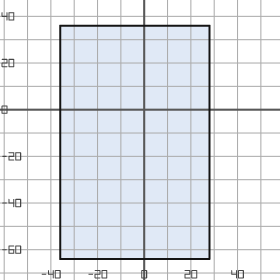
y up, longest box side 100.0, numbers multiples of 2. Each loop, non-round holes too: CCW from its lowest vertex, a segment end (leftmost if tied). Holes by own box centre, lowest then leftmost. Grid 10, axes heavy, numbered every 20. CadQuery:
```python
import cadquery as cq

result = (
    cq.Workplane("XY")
    .moveTo(-36.0, -64.0)
    .lineTo(28.0, -64.0)
    .lineTo(28.0, 36.0)
    .lineTo(-36.0, 36.0)
    .close()
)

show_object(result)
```